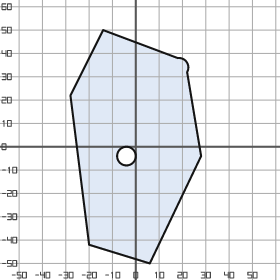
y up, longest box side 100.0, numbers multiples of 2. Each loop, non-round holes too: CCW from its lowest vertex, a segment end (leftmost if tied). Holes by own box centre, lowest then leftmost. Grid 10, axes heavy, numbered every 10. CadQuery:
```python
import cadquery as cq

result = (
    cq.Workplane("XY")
    .moveTo(6.0, -50.0)
    .lineTo(28.0, -4.0)
    .lineTo(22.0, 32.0)
    .threePointArc((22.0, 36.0), (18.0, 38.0))
    .lineTo(-14.0, 50.0)
    .lineTo(-28.0, 22.0)
    .lineTo(-20.0, -42.0)
    .close()
    .moveTo(-4.0, -4.0)
    .circle(4.0)
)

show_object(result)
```